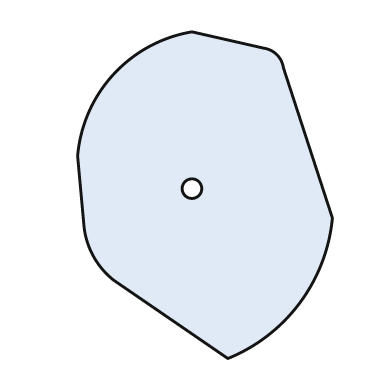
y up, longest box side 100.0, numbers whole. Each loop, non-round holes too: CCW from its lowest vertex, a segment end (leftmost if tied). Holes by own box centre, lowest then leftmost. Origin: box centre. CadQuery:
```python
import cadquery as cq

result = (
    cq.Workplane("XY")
    .moveTo(7.0, -50.0)
    .threePointArc((29.0, -33.0), (39.0, -7.0))
    .lineTo(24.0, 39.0)
    .threePointArc((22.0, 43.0), (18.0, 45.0))
    .lineTo(-4.0, 50.0)
    .threePointArc((-28.0, 37.0), (-39.0, 12.0))
    .lineTo(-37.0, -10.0)
    .threePointArc((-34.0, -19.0), (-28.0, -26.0))
    .close()
    .moveTo(-4.0, 2.0)
    .circle(3.0)
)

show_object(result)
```